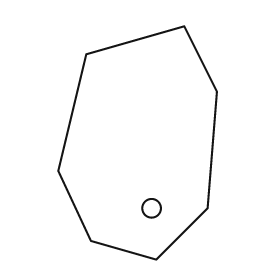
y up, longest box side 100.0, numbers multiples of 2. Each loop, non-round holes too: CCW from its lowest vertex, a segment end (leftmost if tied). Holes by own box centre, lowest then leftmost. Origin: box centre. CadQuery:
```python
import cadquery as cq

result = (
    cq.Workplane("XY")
    .moveTo(8.0, -50.0)
    .lineTo(30.0, -28.0)
    .lineTo(34.0, 22.0)
    .lineTo(20.0, 50.0)
    .lineTo(-22.0, 38.0)
    .lineTo(-34.0, -12.0)
    .lineTo(-20.0, -42.0)
    .close()
    .moveTo(6.0, -28.0)
    .circle(4.0)
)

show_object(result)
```